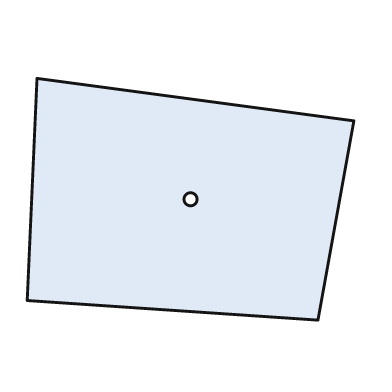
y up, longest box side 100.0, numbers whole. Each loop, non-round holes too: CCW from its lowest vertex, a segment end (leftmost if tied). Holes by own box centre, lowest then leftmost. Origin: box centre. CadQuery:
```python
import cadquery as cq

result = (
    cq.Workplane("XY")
    .moveTo(39.0, -37.0)
    .lineTo(50.0, 24.0)
    .lineTo(-47.0, 37.0)
    .lineTo(-50.0, -31.0)
    .close()
    .moveTo(0.0, 0.0)
    .circle(2.0)
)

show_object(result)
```